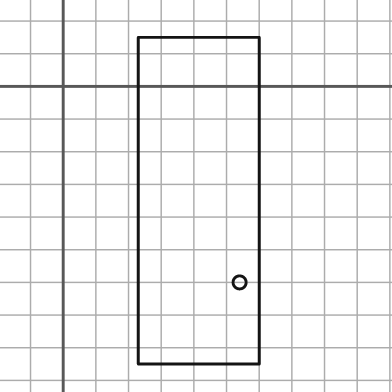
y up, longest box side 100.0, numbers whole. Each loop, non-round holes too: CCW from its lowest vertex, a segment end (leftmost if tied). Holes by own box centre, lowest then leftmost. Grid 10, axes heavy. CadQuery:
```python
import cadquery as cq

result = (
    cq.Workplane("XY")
    .moveTo(23.0, -85.0)
    .lineTo(60.0, -85.0)
    .lineTo(60.0, 15.0)
    .lineTo(23.0, 15.0)
    .close()
    .moveTo(54.0, -60.0)
    .circle(2.0)
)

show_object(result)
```